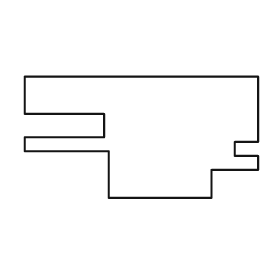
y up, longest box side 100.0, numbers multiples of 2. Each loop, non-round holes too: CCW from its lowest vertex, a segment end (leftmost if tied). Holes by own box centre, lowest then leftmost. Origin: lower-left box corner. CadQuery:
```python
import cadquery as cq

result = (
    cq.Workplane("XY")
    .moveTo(36.0, 0.0)
    .lineTo(80.0, 0.0)
    .lineTo(80.0, 12.0)
    .lineTo(100.0, 12.0)
    .lineTo(100.0, 18.0)
    .lineTo(90.0, 18.0)
    .lineTo(90.0, 24.0)
    .lineTo(100.0, 24.0)
    .lineTo(100.0, 52.0)
    .lineTo(0.0, 52.0)
    .lineTo(0.0, 36.0)
    .lineTo(34.0, 36.0)
    .lineTo(34.0, 26.0)
    .lineTo(0.0, 26.0)
    .lineTo(0.0, 20.0)
    .lineTo(36.0, 20.0)
    .close()
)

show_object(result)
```